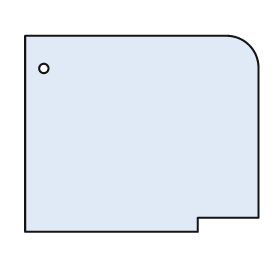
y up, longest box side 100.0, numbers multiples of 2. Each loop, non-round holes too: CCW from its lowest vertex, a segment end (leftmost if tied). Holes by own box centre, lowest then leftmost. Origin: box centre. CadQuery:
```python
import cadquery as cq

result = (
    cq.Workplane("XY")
    .moveTo(-50.0, -42.0)
    .lineTo(24.0, -42.0)
    .lineTo(24.0, -36.0)
    .lineTo(50.0, -36.0)
    .lineTo(50.0, 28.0)
    .threePointArc((46.0, 38.0), (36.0, 42.0))
    .lineTo(-50.0, 42.0)
    .close()
    .moveTo(-42.0, 28.0)
    .circle(2.0)
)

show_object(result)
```